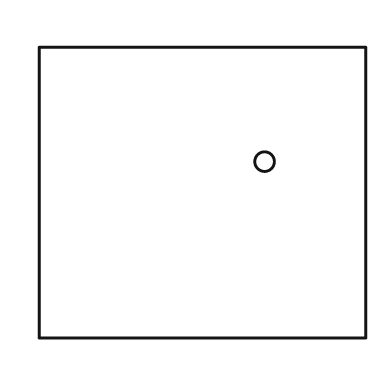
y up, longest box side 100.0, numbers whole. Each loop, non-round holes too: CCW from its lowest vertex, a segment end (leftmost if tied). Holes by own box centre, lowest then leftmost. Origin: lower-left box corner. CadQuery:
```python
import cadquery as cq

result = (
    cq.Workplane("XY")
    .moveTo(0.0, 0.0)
    .lineTo(100.0, 0.0)
    .lineTo(100.0, 89.0)
    .lineTo(0.0, 89.0)
    .close()
    .moveTo(69.0, 54.0)
    .circle(3.0)
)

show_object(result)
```